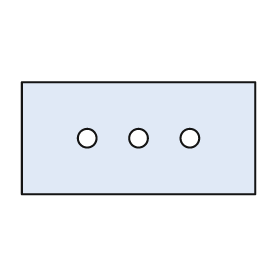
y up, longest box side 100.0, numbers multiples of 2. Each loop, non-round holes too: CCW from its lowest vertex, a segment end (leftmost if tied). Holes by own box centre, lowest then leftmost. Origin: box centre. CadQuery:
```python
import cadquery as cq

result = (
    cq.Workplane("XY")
    .moveTo(-50.0, -24.0)
    .lineTo(50.0, -24.0)
    .lineTo(50.0, 24.0)
    .lineTo(-50.0, 24.0)
    .close()
    .moveTo(-22.0, 0.0)
    .circle(4.0)
    .moveTo(0.0, 0.0)
    .circle(4.0)
    .moveTo(22.0, 0.0)
    .circle(4.0)
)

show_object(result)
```